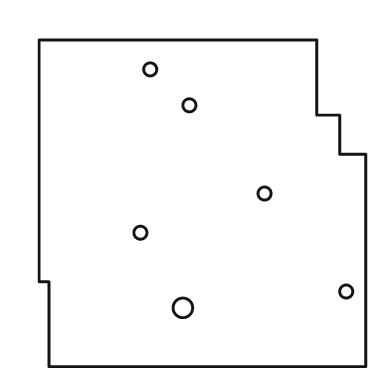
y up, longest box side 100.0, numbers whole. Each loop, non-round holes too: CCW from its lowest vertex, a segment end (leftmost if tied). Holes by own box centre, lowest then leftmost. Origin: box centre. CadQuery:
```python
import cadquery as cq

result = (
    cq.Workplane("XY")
    .moveTo(-47.0, -50.0)
    .lineTo(50.0, -50.0)
    .lineTo(50.0, 15.0)
    .lineTo(42.0, 15.0)
    .lineTo(42.0, 27.0)
    .lineTo(35.0, 27.0)
    .lineTo(35.0, 50.0)
    .lineTo(-50.0, 50.0)
    .lineTo(-50.0, -24.0)
    .lineTo(-47.0, -24.0)
    .close()
    .moveTo(-6.0, -32.0)
    .circle(3.0)
    .moveTo(44.0, -27.0)
    .circle(2.0)
    .moveTo(-19.0, -9.0)
    .circle(2.0)
    .moveTo(19.0, 3.0)
    .circle(2.0)
    .moveTo(-4.0, 30.0)
    .circle(2.0)
    .moveTo(-16.0, 41.0)
    .circle(2.0)
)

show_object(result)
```